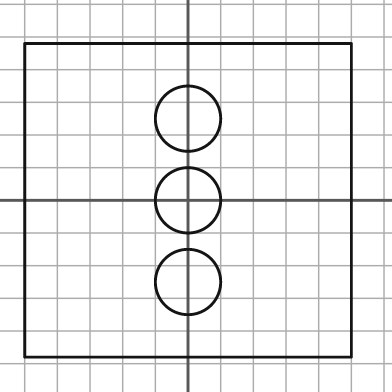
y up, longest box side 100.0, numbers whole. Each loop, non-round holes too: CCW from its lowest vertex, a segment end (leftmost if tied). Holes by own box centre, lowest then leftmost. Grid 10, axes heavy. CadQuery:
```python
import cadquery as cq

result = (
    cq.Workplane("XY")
    .moveTo(-50.0, -48.0)
    .lineTo(50.0, -48.0)
    .lineTo(50.0, 48.0)
    .lineTo(-50.0, 48.0)
    .close()
    .moveTo(0.0, -25.0)
    .circle(10.0)
    .moveTo(0.0, 0.0)
    .circle(10.0)
    .moveTo(0.0, 25.0)
    .circle(10.0)
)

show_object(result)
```